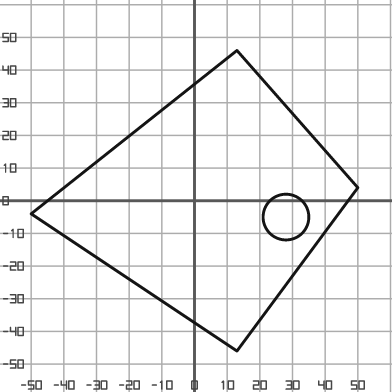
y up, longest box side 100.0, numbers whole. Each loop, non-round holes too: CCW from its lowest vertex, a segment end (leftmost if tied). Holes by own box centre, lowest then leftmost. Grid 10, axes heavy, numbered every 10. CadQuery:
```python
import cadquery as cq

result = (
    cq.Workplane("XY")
    .moveTo(13.0, -46.0)
    .lineTo(50.0, 4.0)
    .lineTo(13.0, 46.0)
    .lineTo(-50.0, -4.0)
    .close()
    .moveTo(28.0, -5.0)
    .circle(7.0)
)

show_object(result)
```